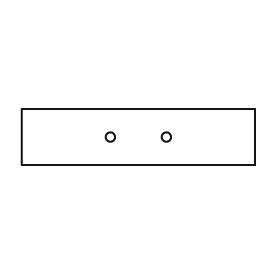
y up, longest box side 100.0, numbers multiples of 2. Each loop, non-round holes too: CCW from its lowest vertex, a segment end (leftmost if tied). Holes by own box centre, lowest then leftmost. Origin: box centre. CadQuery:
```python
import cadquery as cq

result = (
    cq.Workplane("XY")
    .moveTo(-50.0, -12.0)
    .lineTo(50.0, -12.0)
    .lineTo(50.0, 12.0)
    .lineTo(-50.0, 12.0)
    .close()
    .moveTo(-12.0, 0.0)
    .circle(2.0)
    .moveTo(12.0, 0.0)
    .circle(2.0)
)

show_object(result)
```